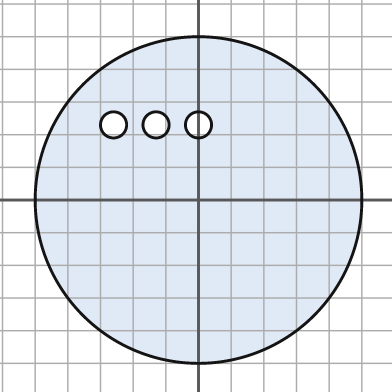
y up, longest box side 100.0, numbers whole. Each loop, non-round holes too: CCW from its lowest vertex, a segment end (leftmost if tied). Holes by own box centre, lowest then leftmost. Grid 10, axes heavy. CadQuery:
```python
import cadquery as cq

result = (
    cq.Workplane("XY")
    .moveTo(0.0, 0.0)
    .circle(50.0)
    .moveTo(-26.0, 23.0)
    .circle(4.0)
    .moveTo(-13.0, 23.0)
    .circle(4.0)
    .moveTo(0.0, 23.0)
    .circle(4.0)
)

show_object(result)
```